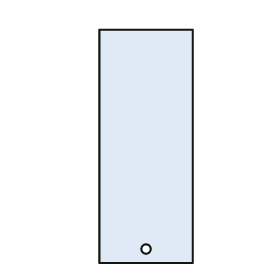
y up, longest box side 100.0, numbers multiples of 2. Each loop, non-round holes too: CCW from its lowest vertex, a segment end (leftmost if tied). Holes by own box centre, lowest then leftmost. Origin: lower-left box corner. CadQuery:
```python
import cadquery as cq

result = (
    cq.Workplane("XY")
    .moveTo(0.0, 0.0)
    .lineTo(40.0, 0.0)
    .lineTo(40.0, 100.0)
    .lineTo(0.0, 100.0)
    .close()
    .moveTo(20.0, 6.0)
    .circle(2.0)
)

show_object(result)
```